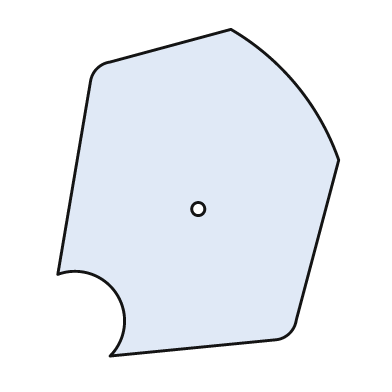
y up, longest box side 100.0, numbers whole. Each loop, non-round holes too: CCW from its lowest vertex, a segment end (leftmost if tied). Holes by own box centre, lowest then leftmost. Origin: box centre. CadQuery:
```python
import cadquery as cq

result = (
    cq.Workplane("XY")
    .moveTo(-27.0, -50.0)
    .lineTo(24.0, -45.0)
    .threePointArc((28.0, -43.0), (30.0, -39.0))
    .lineTo(43.0, 10.0)
    .threePointArc((30.0, 33.0), (10.0, 50.0))
    .lineTo(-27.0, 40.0)
    .threePointArc((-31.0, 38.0), (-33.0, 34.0))
    .lineTo(-43.0, -25.0)
    .threePointArc((-25.0, -31.0), (-27.0, -50.0))
    .close()
    .moveTo(0.0, -5.0)
    .circle(2.0)
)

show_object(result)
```